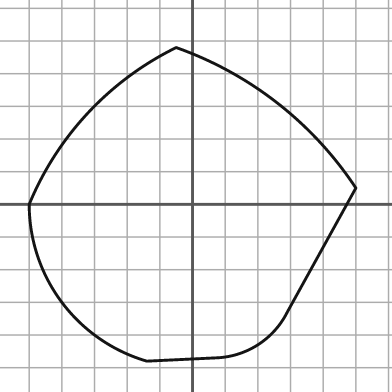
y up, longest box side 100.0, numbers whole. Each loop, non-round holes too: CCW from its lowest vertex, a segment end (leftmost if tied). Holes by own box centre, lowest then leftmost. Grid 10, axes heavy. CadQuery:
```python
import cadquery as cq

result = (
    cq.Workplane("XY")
    .moveTo(-14.0, -48.0)
    .lineTo(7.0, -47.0)
    .threePointArc((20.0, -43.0), (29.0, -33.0))
    .lineTo(50.0, 5.0)
    .threePointArc((26.0, 31.0), (-5.0, 48.0))
    .threePointArc((-32.0, 28.0), (-50.0, 0.0))
    .threePointArc((-40.0, -30.0), (-14.0, -48.0))
    .close()
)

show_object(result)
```